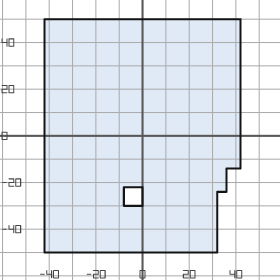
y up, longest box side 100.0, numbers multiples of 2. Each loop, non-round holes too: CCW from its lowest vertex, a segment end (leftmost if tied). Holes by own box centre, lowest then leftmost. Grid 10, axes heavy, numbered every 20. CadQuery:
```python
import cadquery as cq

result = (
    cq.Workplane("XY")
    .moveTo(-42.0, -50.0)
    .lineTo(32.0, -50.0)
    .lineTo(32.0, -24.0)
    .lineTo(36.0, -24.0)
    .lineTo(36.0, -14.0)
    .lineTo(42.0, -14.0)
    .lineTo(42.0, 50.0)
    .lineTo(-42.0, 50.0)
    .close()
    .moveTo(-8.0, -30.0)
    .lineTo(0.0, -30.0)
    .lineTo(0.0, -22.0)
    .lineTo(-8.0, -22.0)
    .close()
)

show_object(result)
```